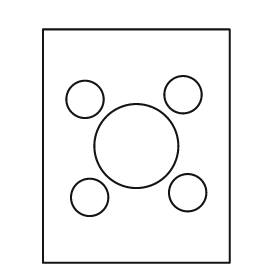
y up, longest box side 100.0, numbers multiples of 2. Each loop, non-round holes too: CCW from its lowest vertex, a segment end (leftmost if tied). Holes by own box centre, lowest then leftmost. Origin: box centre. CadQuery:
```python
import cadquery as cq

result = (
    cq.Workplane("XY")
    .moveTo(-40.0, -50.0)
    .lineTo(40.0, -50.0)
    .lineTo(40.0, 50.0)
    .lineTo(-40.0, 50.0)
    .close()
    .moveTo(-20.0, -22.0)
    .circle(8.0)
    .moveTo(22.0, -20.0)
    .circle(8.0)
    .moveTo(0.0, 0.0)
    .circle(18.0)
    .moveTo(-22.0, 20.0)
    .circle(8.0)
    .moveTo(20.0, 22.0)
    .circle(8.0)
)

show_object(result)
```